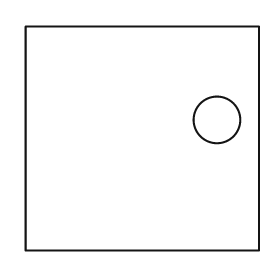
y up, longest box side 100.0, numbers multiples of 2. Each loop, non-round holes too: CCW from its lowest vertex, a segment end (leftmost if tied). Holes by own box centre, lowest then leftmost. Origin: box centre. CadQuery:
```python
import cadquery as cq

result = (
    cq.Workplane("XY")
    .moveTo(-50.0, -48.0)
    .lineTo(50.0, -48.0)
    .lineTo(50.0, 48.0)
    .lineTo(-50.0, 48.0)
    .close()
    .moveTo(32.0, 8.0)
    .circle(10.0)
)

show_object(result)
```